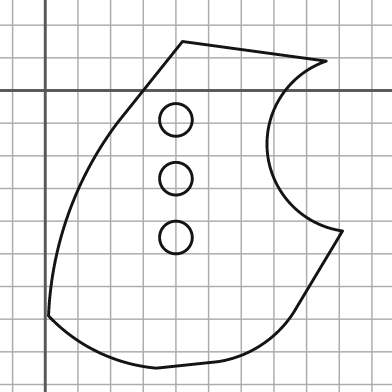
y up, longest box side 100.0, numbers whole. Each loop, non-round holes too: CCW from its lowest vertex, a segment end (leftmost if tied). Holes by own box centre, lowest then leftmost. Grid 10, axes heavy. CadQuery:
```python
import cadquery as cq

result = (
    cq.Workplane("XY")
    .moveTo(34.0, -85.0)
    .lineTo(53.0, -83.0)
    .threePointArc((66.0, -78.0), (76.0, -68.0))
    .lineTo(91.0, -43.0)
    .threePointArc((68.0, -19.0), (86.0, 9.0))
    .lineTo(42.0, 15.0)
    .lineTo(22.0, -10.0)
    .threePointArc((7.0, -38.0), (1.0, -69.0))
    .threePointArc((16.0, -80.0), (34.0, -85.0))
    .close()
    .moveTo(40.0, -45.0)
    .circle(5.0)
    .moveTo(40.0, -27.0)
    .circle(5.0)
    .moveTo(40.0, -9.0)
    .circle(5.0)
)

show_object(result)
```